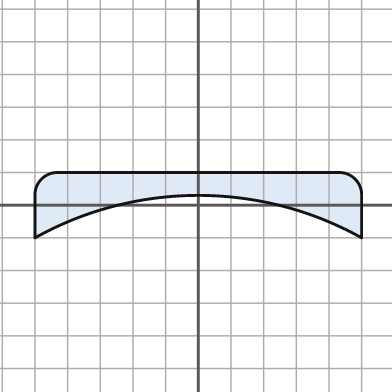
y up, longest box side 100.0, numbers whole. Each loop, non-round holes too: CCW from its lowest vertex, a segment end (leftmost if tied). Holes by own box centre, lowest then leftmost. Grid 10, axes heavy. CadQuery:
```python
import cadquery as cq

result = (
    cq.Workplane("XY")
    .moveTo(-50.0, -10.0)
    .threePointArc((0.0, 3.0), (50.0, -10.0))
    .lineTo(50.0, 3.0)
    .threePointArc((48.0, 8.0), (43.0, 10.0))
    .lineTo(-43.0, 10.0)
    .threePointArc((-48.0, 8.0), (-50.0, 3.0))
    .close()
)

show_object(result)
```